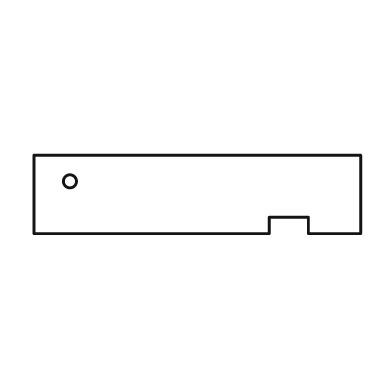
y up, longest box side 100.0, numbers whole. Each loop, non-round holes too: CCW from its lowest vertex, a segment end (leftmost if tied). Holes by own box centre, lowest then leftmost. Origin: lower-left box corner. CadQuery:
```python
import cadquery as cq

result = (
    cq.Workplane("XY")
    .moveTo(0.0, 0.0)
    .lineTo(72.0, 0.0)
    .lineTo(72.0, 5.0)
    .lineTo(84.0, 5.0)
    .lineTo(84.0, 0.0)
    .lineTo(100.0, 0.0)
    .lineTo(100.0, 24.0)
    .lineTo(0.0, 24.0)
    .close()
    .moveTo(11.0, 16.0)
    .circle(2.0)
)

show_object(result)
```